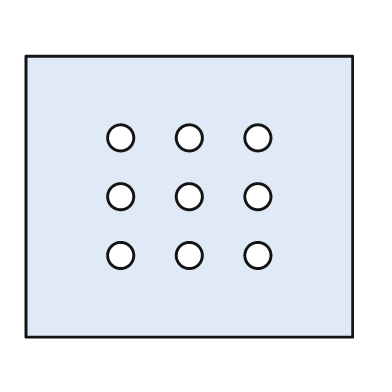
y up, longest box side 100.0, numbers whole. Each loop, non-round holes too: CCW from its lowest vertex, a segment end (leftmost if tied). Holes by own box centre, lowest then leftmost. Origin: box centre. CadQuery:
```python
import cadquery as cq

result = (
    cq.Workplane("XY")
    .moveTo(-50.0, -43.0)
    .lineTo(50.0, -43.0)
    .lineTo(50.0, 43.0)
    .lineTo(-50.0, 43.0)
    .close()
    .moveTo(-21.0, -18.0)
    .circle(4.0)
    .moveTo(0.0, -18.0)
    .circle(4.0)
    .moveTo(21.0, -18.0)
    .circle(4.0)
    .moveTo(-21.0, 0.0)
    .circle(4.0)
    .moveTo(0.0, 0.0)
    .circle(4.0)
    .moveTo(21.0, 0.0)
    .circle(4.0)
    .moveTo(-21.0, 18.0)
    .circle(4.0)
    .moveTo(0.0, 18.0)
    .circle(4.0)
    .moveTo(21.0, 18.0)
    .circle(4.0)
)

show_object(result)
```